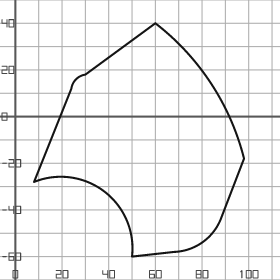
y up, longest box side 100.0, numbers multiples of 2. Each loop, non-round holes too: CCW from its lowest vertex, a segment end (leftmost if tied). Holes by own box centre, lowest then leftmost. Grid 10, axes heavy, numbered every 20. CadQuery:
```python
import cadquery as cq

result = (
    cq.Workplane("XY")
    .moveTo(50.0, -60.0)
    .lineTo(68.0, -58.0)
    .threePointArc((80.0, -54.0), (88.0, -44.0))
    .lineTo(98.0, -18.0)
    .threePointArc((84.0, 14.0), (60.0, 40.0))
    .lineTo(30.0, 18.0)
    .threePointArc((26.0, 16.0), (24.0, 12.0))
    .lineTo(8.0, -28.0)
    .threePointArc((38.0, -32.0), (50.0, -60.0))
    .close()
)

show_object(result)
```